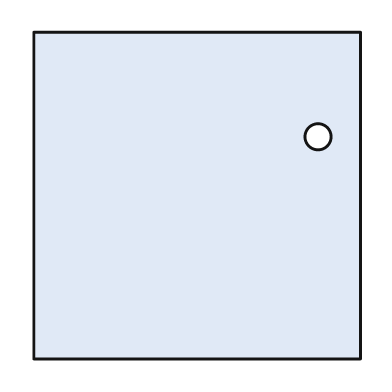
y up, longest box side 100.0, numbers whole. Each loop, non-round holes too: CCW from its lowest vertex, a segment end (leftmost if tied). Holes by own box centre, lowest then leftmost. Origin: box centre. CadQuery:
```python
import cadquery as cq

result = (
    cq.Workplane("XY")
    .moveTo(-50.0, -50.0)
    .lineTo(50.0, -50.0)
    .lineTo(50.0, 50.0)
    .lineTo(-50.0, 50.0)
    .close()
    .moveTo(37.0, 18.0)
    .circle(4.0)
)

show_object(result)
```